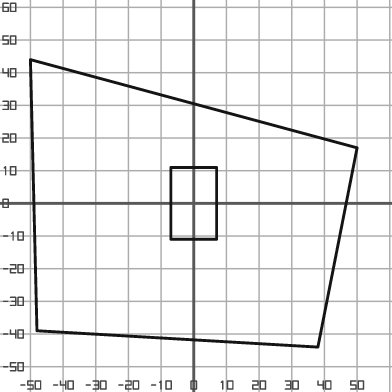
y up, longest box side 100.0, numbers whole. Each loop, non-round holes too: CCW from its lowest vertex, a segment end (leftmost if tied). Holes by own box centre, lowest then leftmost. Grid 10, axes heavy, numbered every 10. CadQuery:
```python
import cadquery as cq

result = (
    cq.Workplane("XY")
    .moveTo(38.0, -44.0)
    .lineTo(50.0, 17.0)
    .lineTo(-50.0, 44.0)
    .lineTo(-48.0, -39.0)
    .close()
    .moveTo(-7.0, -11.0)
    .lineTo(7.0, -11.0)
    .lineTo(7.0, 11.0)
    .lineTo(-7.0, 11.0)
    .close()
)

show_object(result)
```